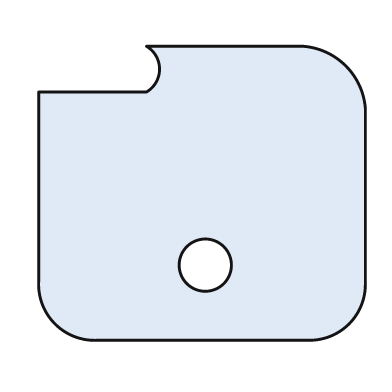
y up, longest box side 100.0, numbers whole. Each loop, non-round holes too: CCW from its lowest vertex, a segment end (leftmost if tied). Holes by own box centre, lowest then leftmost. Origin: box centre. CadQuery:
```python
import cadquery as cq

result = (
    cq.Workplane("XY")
    .moveTo(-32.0, -45.0)
    .lineTo(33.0, -45.0)
    .threePointArc((45.0, -40.0), (50.0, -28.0))
    .lineTo(50.0, 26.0)
    .threePointArc((44.0, 39.0), (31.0, 45.0))
    .lineTo(-17.0, 45.0)
    .threePointArc((-13.0, 38.0), (-17.0, 31.0))
    .lineTo(-50.0, 31.0)
    .lineTo(-50.0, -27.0)
    .threePointArc((-45.0, -40.0), (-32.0, -45.0))
    .close()
    .moveTo(1.0, -22.0)
    .circle(8.0)
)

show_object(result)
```